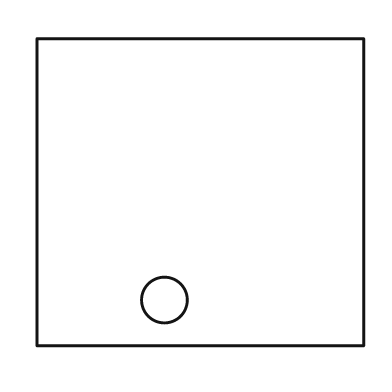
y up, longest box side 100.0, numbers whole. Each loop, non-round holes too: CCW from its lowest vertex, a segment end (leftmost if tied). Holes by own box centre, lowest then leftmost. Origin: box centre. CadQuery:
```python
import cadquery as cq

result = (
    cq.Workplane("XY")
    .moveTo(-50.0, -47.0)
    .lineTo(50.0, -47.0)
    .lineTo(50.0, 47.0)
    .lineTo(-50.0, 47.0)
    .close()
    .moveTo(-11.0, -33.0)
    .circle(7.0)
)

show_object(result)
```